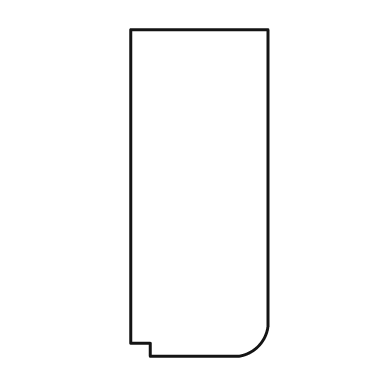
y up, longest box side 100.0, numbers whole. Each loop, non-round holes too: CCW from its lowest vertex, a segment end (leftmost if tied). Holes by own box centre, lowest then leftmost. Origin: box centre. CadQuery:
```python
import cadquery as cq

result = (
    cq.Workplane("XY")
    .moveTo(-15.0, -50.0)
    .lineTo(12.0, -50.0)
    .threePointArc((18.0, -47.0), (21.0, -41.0))
    .lineTo(21.0, 50.0)
    .lineTo(-21.0, 50.0)
    .lineTo(-21.0, -46.0)
    .lineTo(-15.0, -46.0)
    .close()
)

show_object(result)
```